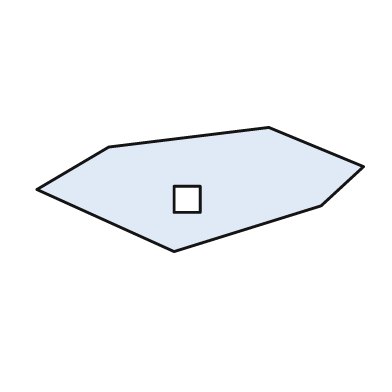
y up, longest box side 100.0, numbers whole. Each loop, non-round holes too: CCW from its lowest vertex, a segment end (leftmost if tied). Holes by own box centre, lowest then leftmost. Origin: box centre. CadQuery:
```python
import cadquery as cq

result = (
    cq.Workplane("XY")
    .moveTo(-8.0, -19.0)
    .lineTo(37.0, -5.0)
    .lineTo(50.0, 7.0)
    .lineTo(21.0, 19.0)
    .lineTo(-28.0, 13.0)
    .lineTo(-50.0, 0.0)
    .close()
    .moveTo(-8.0, -7.0)
    .lineTo(0.0, -7.0)
    .lineTo(0.0, 1.0)
    .lineTo(-8.0, 1.0)
    .close()
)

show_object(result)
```